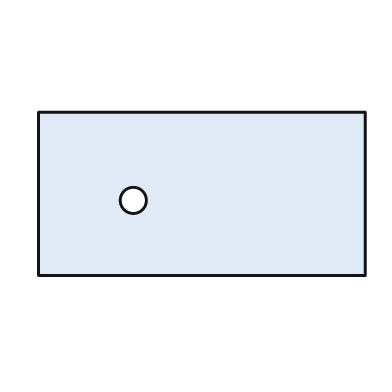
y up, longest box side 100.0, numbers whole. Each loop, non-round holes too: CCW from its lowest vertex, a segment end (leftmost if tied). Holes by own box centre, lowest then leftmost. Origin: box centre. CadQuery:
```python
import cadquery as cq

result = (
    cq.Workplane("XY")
    .moveTo(-50.0, -25.0)
    .lineTo(50.0, -25.0)
    .lineTo(50.0, 25.0)
    .lineTo(-50.0, 25.0)
    .close()
    .moveTo(-21.0, -2.0)
    .circle(4.0)
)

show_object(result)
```